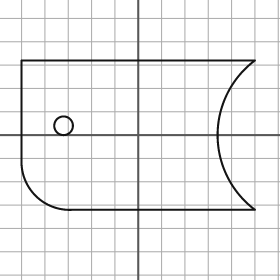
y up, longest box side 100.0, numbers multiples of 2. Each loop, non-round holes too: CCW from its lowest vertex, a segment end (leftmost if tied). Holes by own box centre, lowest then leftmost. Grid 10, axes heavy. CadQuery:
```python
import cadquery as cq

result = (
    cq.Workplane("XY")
    .moveTo(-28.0, -32.0)
    .lineTo(50.0, -32.0)
    .threePointArc((34.0, 0.0), (50.0, 32.0))
    .lineTo(-50.0, 32.0)
    .lineTo(-50.0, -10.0)
    .threePointArc((-44.0, -26.0), (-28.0, -32.0))
    .close()
    .moveTo(-32.0, 4.0)
    .circle(4.0)
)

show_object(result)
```